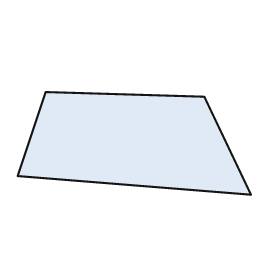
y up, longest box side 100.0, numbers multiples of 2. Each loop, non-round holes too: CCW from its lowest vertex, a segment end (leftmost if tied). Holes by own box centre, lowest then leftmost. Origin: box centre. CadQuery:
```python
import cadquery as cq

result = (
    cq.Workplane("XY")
    .moveTo(50.0, -22.0)
    .lineTo(30.0, 20.0)
    .lineTo(-38.0, 22.0)
    .lineTo(-50.0, -14.0)
    .close()
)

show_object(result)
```